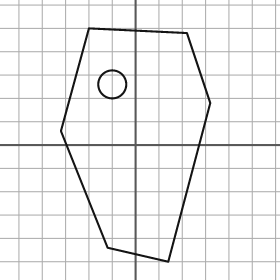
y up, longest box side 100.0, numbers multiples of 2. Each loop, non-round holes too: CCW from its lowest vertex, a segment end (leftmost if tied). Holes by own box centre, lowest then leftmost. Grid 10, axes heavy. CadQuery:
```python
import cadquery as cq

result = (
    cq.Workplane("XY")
    .moveTo(14.0, -50.0)
    .lineTo(32.0, 18.0)
    .lineTo(22.0, 48.0)
    .lineTo(-20.0, 50.0)
    .lineTo(-32.0, 6.0)
    .lineTo(-12.0, -44.0)
    .close()
    .moveTo(-10.0, 26.0)
    .circle(6.0)
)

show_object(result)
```